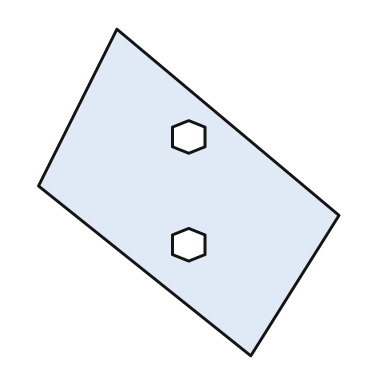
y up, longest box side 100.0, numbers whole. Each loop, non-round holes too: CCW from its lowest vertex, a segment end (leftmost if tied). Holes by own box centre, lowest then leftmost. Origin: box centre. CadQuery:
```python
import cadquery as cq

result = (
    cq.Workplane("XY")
    .moveTo(19.0, -50.0)
    .lineTo(46.0, -7.0)
    .lineTo(-22.0, 50.0)
    .lineTo(-46.0, 2.0)
    .close()
    .moveTo(0.0, -21.0)
    .lineTo(5.0, -19.0)
    .lineTo(5.0, -13.0)
    .lineTo(0.0, -11.0)
    .lineTo(-5.0, -13.0)
    .lineTo(-5.0, -19.0)
    .close()
    .moveTo(0.0, 12.0)
    .lineTo(5.0, 14.0)
    .lineTo(5.0, 20.0)
    .lineTo(0.0, 22.0)
    .lineTo(-5.0, 20.0)
    .lineTo(-5.0, 14.0)
    .close()
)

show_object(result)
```